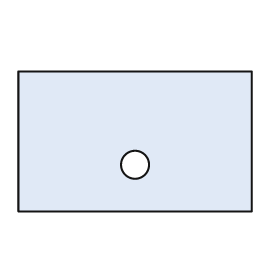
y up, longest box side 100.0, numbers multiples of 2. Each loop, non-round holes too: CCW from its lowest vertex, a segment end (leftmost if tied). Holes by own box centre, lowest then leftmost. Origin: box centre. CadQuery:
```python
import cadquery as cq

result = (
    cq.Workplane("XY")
    .moveTo(-50.0, -30.0)
    .lineTo(50.0, -30.0)
    .lineTo(50.0, 30.0)
    .lineTo(-50.0, 30.0)
    .close()
    .moveTo(0.0, -10.0)
    .circle(6.0)
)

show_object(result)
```